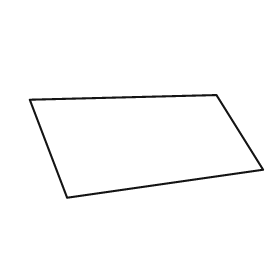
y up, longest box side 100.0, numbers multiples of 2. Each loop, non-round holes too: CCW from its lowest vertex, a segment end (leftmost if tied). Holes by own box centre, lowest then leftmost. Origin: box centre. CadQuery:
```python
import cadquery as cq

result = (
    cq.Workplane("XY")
    .moveTo(-34.0, -22.0)
    .lineTo(50.0, -10.0)
    .lineTo(30.0, 22.0)
    .lineTo(-50.0, 20.0)
    .close()
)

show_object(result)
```